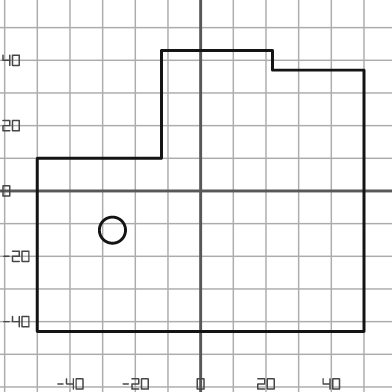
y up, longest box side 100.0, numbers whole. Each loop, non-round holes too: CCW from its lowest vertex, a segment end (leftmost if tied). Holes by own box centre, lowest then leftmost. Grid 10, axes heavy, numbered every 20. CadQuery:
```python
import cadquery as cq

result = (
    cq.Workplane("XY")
    .moveTo(-50.0, -43.0)
    .lineTo(50.0, -43.0)
    .lineTo(50.0, 37.0)
    .lineTo(22.0, 37.0)
    .lineTo(22.0, 43.0)
    .lineTo(-12.0, 43.0)
    .lineTo(-12.0, 10.0)
    .lineTo(-50.0, 10.0)
    .close()
    .moveTo(-27.0, -12.0)
    .circle(4.0)
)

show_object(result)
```